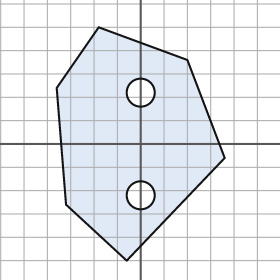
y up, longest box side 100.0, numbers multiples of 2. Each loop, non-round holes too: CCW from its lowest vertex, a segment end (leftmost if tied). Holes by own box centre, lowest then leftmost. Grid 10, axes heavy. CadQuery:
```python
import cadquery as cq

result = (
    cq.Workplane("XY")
    .moveTo(-6.0, -50.0)
    .lineTo(36.0, -6.0)
    .lineTo(20.0, 36.0)
    .lineTo(-18.0, 50.0)
    .lineTo(-36.0, 24.0)
    .lineTo(-32.0, -26.0)
    .close()
    .moveTo(0.0, -22.0)
    .circle(6.0)
    .moveTo(0.0, 22.0)
    .circle(6.0)
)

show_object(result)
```